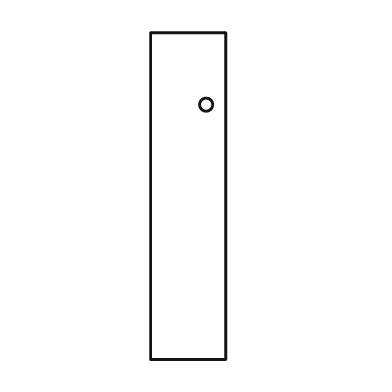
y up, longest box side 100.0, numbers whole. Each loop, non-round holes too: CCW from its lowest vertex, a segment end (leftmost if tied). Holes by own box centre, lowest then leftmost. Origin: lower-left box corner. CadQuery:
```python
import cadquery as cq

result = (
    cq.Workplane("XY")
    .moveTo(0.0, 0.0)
    .lineTo(23.0, 0.0)
    .lineTo(23.0, 100.0)
    .lineTo(0.0, 100.0)
    .close()
    .moveTo(17.0, 78.0)
    .circle(2.0)
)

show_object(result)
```